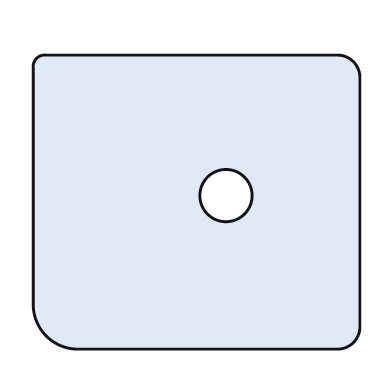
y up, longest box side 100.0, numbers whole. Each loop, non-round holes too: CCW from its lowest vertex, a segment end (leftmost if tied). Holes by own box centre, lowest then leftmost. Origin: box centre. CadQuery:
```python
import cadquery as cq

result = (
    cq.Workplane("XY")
    .moveTo(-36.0, -45.0)
    .lineTo(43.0, -45.0)
    .threePointArc((48.0, -43.0), (50.0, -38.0))
    .lineTo(50.0, 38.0)
    .threePointArc((48.0, 43.0), (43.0, 45.0))
    .lineTo(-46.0, 45.0)
    .threePointArc((-49.0, 44.0), (-50.0, 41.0))
    .lineTo(-50.0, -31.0)
    .threePointArc((-46.0, -41.0), (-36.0, -45.0))
    .close()
    .moveTo(9.0, 2.0)
    .circle(8.0)
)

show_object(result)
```